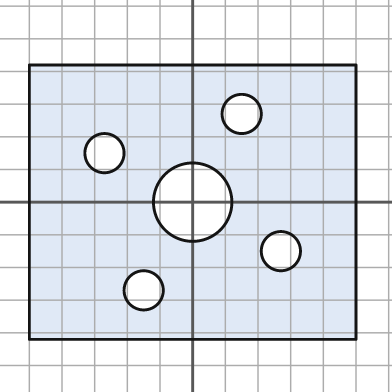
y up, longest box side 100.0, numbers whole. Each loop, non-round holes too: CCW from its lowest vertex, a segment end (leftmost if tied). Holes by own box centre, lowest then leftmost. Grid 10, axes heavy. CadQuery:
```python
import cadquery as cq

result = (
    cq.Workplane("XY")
    .moveTo(-50.0, -42.0)
    .lineTo(50.0, -42.0)
    .lineTo(50.0, 42.0)
    .lineTo(-50.0, 42.0)
    .close()
    .moveTo(-15.0, -27.0)
    .circle(6.0)
    .moveTo(27.0, -15.0)
    .circle(6.0)
    .moveTo(0.0, 0.0)
    .circle(12.0)
    .moveTo(-27.0, 15.0)
    .circle(6.0)
    .moveTo(15.0, 27.0)
    .circle(6.0)
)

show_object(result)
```